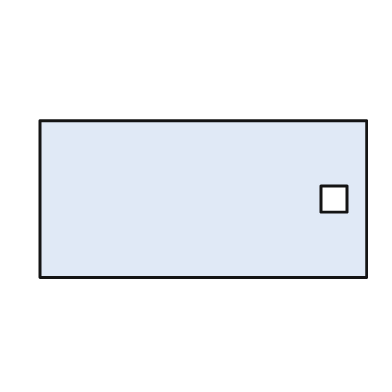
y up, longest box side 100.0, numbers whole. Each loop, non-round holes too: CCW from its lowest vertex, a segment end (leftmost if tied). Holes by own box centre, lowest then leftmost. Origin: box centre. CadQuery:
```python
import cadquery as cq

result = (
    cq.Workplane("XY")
    .moveTo(-50.0, -24.0)
    .lineTo(50.0, -24.0)
    .lineTo(50.0, 24.0)
    .lineTo(-50.0, 24.0)
    .close()
    .moveTo(36.0, -4.0)
    .lineTo(44.0, -4.0)
    .lineTo(44.0, 4.0)
    .lineTo(36.0, 4.0)
    .close()
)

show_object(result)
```